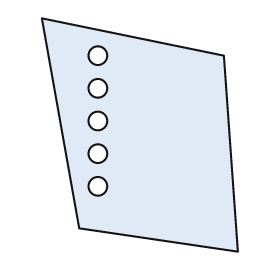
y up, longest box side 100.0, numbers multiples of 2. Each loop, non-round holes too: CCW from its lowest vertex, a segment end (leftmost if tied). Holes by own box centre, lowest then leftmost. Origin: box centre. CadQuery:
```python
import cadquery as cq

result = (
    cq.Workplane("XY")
    .moveTo(42.0, -50.0)
    .lineTo(36.0, 34.0)
    .lineTo(-42.0, 50.0)
    .lineTo(-26.0, -40.0)
    .close()
    .moveTo(-18.0, -22.0)
    .circle(4.0)
    .moveTo(-18.0, -8.0)
    .circle(4.0)
    .moveTo(-18.0, 6.0)
    .circle(4.0)
    .moveTo(-18.0, 20.0)
    .circle(4.0)
    .moveTo(-18.0, 34.0)
    .circle(4.0)
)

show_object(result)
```